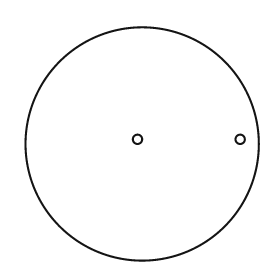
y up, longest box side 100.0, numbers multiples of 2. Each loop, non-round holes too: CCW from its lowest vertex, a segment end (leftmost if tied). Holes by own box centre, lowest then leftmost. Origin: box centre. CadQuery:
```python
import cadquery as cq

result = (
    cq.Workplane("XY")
    .moveTo(0.0, 0.0)
    .circle(50.0)
    .moveTo(-2.0, 2.0)
    .circle(2.0)
    .moveTo(42.0, 2.0)
    .circle(2.0)
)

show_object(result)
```